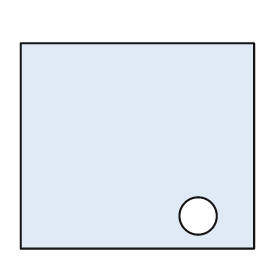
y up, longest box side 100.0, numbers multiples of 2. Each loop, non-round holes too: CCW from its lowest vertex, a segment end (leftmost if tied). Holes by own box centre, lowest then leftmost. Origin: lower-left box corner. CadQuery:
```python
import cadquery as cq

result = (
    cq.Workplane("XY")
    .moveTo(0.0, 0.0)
    .lineTo(100.0, 0.0)
    .lineTo(100.0, 88.0)
    .lineTo(0.0, 88.0)
    .close()
    .moveTo(76.0, 14.0)
    .circle(8.0)
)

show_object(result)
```